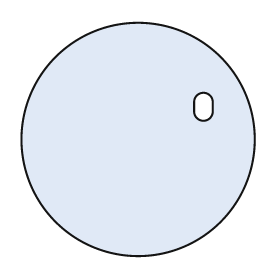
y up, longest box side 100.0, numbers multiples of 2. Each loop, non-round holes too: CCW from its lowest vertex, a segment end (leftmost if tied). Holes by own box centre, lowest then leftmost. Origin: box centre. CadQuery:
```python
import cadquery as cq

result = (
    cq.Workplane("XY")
    .moveTo(0.0, 0.0)
    .circle(50.0)
    .moveTo(24.0, 12.0)
    .threePointArc((28.0, 8.0), (32.0, 12.0))
    .lineTo(32.0, 16.0)
    .threePointArc((28.0, 20.0), (24.0, 16.0))
    .close()
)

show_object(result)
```